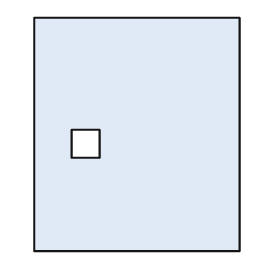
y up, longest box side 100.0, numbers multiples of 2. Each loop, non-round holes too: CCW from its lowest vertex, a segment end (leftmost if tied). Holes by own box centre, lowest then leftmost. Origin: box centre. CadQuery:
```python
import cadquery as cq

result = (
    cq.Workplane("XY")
    .moveTo(-44.0, -50.0)
    .lineTo(44.0, -50.0)
    .lineTo(44.0, 50.0)
    .lineTo(-44.0, 50.0)
    .close()
    .moveTo(-28.0, -10.0)
    .lineTo(-16.0, -10.0)
    .lineTo(-16.0, 2.0)
    .lineTo(-28.0, 2.0)
    .close()
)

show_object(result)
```